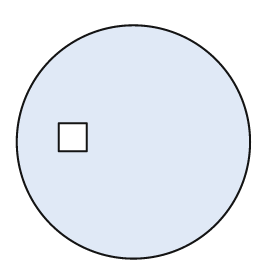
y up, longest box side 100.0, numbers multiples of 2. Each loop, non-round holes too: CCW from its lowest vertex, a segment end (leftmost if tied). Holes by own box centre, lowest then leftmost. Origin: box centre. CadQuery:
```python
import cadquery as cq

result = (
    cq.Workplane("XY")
    .moveTo(0.0, 0.0)
    .circle(50.0)
    .moveTo(-32.0, -4.0)
    .lineTo(-20.0, -4.0)
    .lineTo(-20.0, 8.0)
    .lineTo(-32.0, 8.0)
    .close()
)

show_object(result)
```